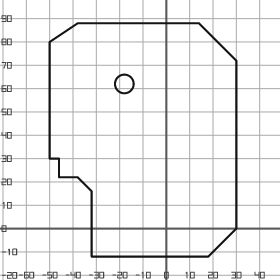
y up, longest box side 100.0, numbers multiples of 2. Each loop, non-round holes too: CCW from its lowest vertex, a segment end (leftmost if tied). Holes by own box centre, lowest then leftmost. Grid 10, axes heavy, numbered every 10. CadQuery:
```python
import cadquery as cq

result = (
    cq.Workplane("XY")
    .moveTo(-32.0, -12.0)
    .lineTo(18.0, -12.0)
    .lineTo(30.0, 0.0)
    .lineTo(30.0, 72.0)
    .lineTo(14.0, 88.0)
    .lineTo(-38.0, 88.0)
    .lineTo(-50.0, 80.0)
    .lineTo(-50.0, 30.0)
    .lineTo(-46.0, 30.0)
    .lineTo(-46.0, 22.0)
    .lineTo(-38.0, 22.0)
    .lineTo(-32.0, 16.0)
    .close()
    .moveTo(-18.0, 62.0)
    .circle(4.0)
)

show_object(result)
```